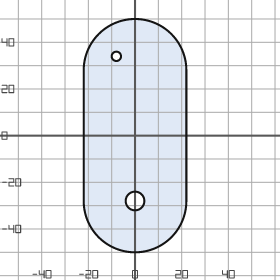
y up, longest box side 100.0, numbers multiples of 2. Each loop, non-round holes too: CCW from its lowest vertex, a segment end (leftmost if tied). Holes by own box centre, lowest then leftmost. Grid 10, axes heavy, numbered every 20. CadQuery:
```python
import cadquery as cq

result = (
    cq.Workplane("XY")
    .moveTo(-22.0, -28.0)
    .threePointArc((0.0, -50.0), (22.0, -28.0))
    .lineTo(22.0, 28.0)
    .threePointArc((0.0, 50.0), (-22.0, 28.0))
    .close()
    .moveTo(0.0, -28.0)
    .circle(4.0)
    .moveTo(-8.0, 34.0)
    .circle(2.0)
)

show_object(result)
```